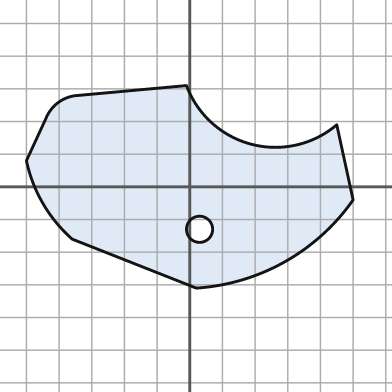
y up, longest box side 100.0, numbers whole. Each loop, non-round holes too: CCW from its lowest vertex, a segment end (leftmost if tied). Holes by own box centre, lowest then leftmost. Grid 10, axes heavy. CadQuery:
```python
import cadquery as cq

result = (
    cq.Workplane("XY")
    .moveTo(2.0, -31.0)
    .threePointArc((29.0, -23.0), (50.0, -4.0))
    .lineTo(45.0, 19.0)
    .threePointArc((19.0, 13.0), (-1.0, 31.0))
    .lineTo(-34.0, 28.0)
    .threePointArc((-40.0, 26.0), (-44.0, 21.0))
    .lineTo(-50.0, 8.0)
    .threePointArc((-45.0, -5.0), (-36.0, -16.0))
    .close()
    .moveTo(3.0, -13.0)
    .circle(4.0)
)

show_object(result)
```